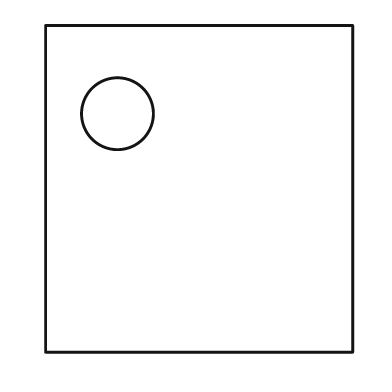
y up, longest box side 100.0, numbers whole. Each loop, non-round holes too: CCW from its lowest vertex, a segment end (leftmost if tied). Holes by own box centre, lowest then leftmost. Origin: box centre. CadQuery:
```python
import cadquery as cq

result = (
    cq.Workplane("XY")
    .moveTo(-47.0, -50.0)
    .lineTo(47.0, -50.0)
    .lineTo(47.0, 50.0)
    .lineTo(-47.0, 50.0)
    .close()
    .moveTo(-25.0, 23.0)
    .circle(11.0)
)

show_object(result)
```